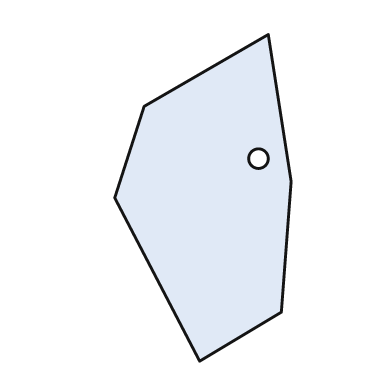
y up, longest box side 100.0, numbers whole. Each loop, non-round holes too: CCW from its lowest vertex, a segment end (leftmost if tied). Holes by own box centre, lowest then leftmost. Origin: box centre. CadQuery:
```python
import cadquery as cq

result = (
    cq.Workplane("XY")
    .moveTo(-1.0, -50.0)
    .lineTo(24.0, -35.0)
    .lineTo(27.0, 5.0)
    .lineTo(20.0, 50.0)
    .lineTo(-18.0, 28.0)
    .lineTo(-27.0, 0.0)
    .close()
    .moveTo(17.0, 12.0)
    .circle(3.0)
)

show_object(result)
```